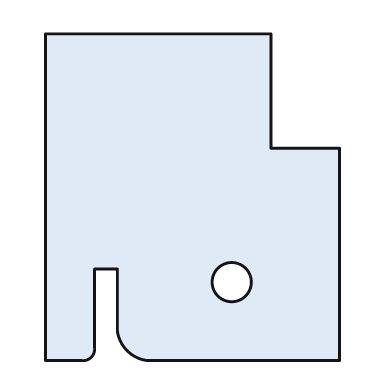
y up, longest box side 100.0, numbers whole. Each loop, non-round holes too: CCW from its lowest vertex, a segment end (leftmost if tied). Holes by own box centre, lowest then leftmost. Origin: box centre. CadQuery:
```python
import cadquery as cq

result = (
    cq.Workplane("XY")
    .moveTo(-45.0, -50.0)
    .lineTo(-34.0, -50.0)
    .threePointArc((-31.0, -49.0), (-30.0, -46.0))
    .lineTo(-30.0, -22.0)
    .lineTo(-23.0, -22.0)
    .lineTo(-23.0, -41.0)
    .threePointArc((-20.0, -47.0), (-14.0, -50.0))
    .lineTo(45.0, -50.0)
    .lineTo(45.0, 15.0)
    .lineTo(24.0, 15.0)
    .lineTo(24.0, 50.0)
    .lineTo(-45.0, 50.0)
    .close()
    .moveTo(12.0, -26.0)
    .circle(6.0)
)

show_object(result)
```